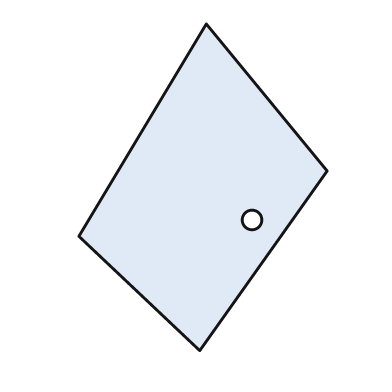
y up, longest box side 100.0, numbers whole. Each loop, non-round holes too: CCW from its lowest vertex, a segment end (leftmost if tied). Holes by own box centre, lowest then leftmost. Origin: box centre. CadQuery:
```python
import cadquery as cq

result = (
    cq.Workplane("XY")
    .moveTo(-1.0, -50.0)
    .lineTo(38.0, 5.0)
    .lineTo(1.0, 50.0)
    .lineTo(-38.0, -15.0)
    .close()
    .moveTo(15.0, -10.0)
    .circle(3.0)
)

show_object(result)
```